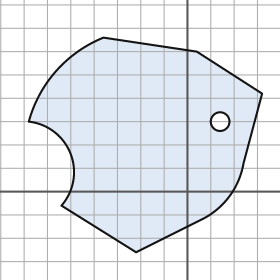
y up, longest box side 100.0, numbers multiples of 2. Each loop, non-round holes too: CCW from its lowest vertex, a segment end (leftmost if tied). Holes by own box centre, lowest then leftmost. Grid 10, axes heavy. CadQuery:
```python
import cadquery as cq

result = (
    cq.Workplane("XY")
    .moveTo(-22.0, -26.0)
    .lineTo(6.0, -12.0)
    .threePointArc((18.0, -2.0), (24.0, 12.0))
    .lineTo(32.0, 42.0)
    .lineTo(4.0, 60.0)
    .lineTo(-36.0, 66.0)
    .threePointArc((-56.0, 52.0), (-68.0, 30.0))
    .threePointArc((-50.0, 16.0), (-54.0, -6.0))
    .close()
    .moveTo(14.0, 30.0)
    .circle(4.0)
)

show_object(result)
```